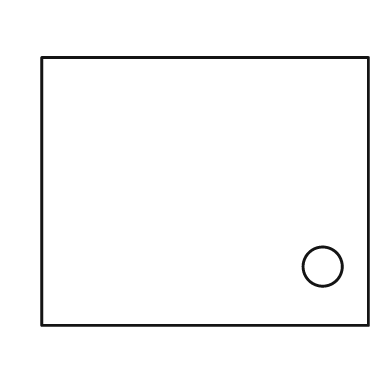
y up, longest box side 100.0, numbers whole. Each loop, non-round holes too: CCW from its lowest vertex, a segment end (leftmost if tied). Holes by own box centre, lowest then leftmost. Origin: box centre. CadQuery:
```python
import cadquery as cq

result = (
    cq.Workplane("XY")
    .moveTo(-50.0, -41.0)
    .lineTo(50.0, -41.0)
    .lineTo(50.0, 41.0)
    .lineTo(-50.0, 41.0)
    .close()
    .moveTo(36.0, -23.0)
    .circle(6.0)
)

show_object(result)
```